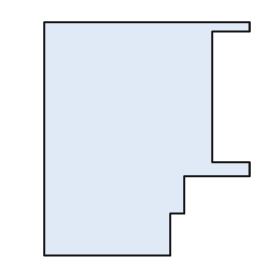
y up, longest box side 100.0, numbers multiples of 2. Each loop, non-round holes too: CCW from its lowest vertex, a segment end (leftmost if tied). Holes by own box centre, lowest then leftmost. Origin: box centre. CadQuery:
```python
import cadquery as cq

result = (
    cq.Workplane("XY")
    .moveTo(-44.0, -50.0)
    .lineTo(10.0, -50.0)
    .lineTo(10.0, -32.0)
    .lineTo(16.0, -32.0)
    .lineTo(16.0, -16.0)
    .lineTo(44.0, -16.0)
    .lineTo(44.0, -10.0)
    .lineTo(28.0, -10.0)
    .lineTo(28.0, 46.0)
    .lineTo(44.0, 46.0)
    .lineTo(44.0, 50.0)
    .lineTo(-44.0, 50.0)
    .close()
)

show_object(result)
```